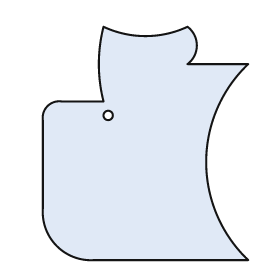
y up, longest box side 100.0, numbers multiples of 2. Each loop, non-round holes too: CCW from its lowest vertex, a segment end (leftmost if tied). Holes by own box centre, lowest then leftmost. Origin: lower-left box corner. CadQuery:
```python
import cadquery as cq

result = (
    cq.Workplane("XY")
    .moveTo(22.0, 0.0)
    .lineTo(88.0, 0.0)
    .threePointArc((70.0, 42.0), (88.0, 84.0))
    .lineTo(62.0, 84.0)
    .threePointArc((66.0, 92.0), (62.0, 100.0))
    .threePointArc((44.0, 96.0), (26.0, 100.0))
    .threePointArc((24.0, 84.0), (26.0, 68.0))
    .lineTo(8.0, 68.0)
    .threePointArc((2.0, 66.0), (0.0, 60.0))
    .lineTo(0.0, 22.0)
    .threePointArc((6.0, 6.0), (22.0, 0.0))
    .close()
    .moveTo(28.0, 62.0)
    .circle(2.0)
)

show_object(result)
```